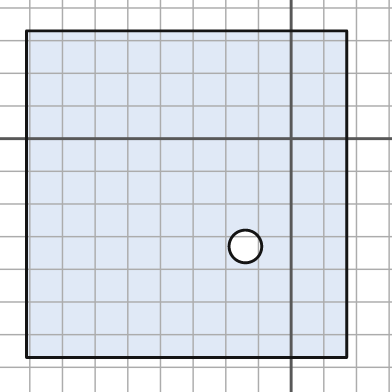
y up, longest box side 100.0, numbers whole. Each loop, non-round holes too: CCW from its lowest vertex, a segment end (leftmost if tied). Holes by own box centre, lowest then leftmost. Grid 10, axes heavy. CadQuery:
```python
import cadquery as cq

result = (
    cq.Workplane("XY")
    .moveTo(-81.0, -67.0)
    .lineTo(17.0, -67.0)
    .lineTo(17.0, 33.0)
    .lineTo(-81.0, 33.0)
    .close()
    .moveTo(-14.0, -33.0)
    .circle(5.0)
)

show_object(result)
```